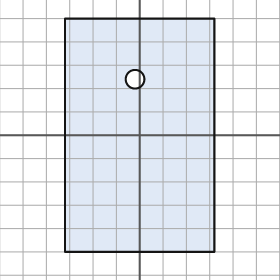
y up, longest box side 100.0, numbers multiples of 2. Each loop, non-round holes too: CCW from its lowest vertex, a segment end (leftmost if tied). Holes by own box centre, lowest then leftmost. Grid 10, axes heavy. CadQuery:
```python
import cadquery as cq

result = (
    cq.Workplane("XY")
    .moveTo(-32.0, -50.0)
    .lineTo(32.0, -50.0)
    .lineTo(32.0, 50.0)
    .lineTo(-32.0, 50.0)
    .close()
    .moveTo(-2.0, 24.0)
    .circle(4.0)
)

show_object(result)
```